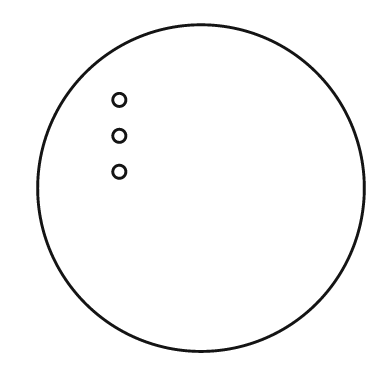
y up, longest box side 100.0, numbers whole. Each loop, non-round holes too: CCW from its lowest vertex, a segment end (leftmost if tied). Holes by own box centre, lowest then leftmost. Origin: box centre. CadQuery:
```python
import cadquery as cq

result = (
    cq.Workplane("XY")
    .moveTo(0.0, 0.0)
    .circle(50.0)
    .moveTo(-25.0, 5.0)
    .circle(2.0)
    .moveTo(-25.0, 16.0)
    .circle(2.0)
    .moveTo(-25.0, 27.0)
    .circle(2.0)
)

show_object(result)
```